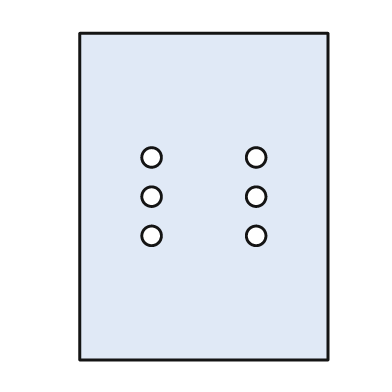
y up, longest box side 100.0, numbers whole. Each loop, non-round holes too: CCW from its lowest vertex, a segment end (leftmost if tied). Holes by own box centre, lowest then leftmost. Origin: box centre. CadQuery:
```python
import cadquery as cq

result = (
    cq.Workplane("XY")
    .moveTo(-38.0, -50.0)
    .lineTo(38.0, -50.0)
    .lineTo(38.0, 50.0)
    .lineTo(-38.0, 50.0)
    .close()
    .moveTo(-16.0, -12.0)
    .circle(3.0)
    .moveTo(16.0, -12.0)
    .circle(3.0)
    .moveTo(-16.0, 0.0)
    .circle(3.0)
    .moveTo(16.0, 0.0)
    .circle(3.0)
    .moveTo(-16.0, 12.0)
    .circle(3.0)
    .moveTo(16.0, 12.0)
    .circle(3.0)
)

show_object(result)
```